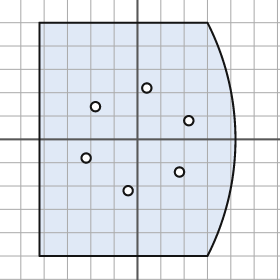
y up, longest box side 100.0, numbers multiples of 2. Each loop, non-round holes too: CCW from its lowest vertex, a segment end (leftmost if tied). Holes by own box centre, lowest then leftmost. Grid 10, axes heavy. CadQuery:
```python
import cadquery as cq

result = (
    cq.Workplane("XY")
    .moveTo(-42.0, -50.0)
    .lineTo(30.0, -50.0)
    .threePointArc((42.0, 0.0), (30.0, 50.0))
    .lineTo(-42.0, 50.0)
    .close()
    .moveTo(-4.0, -22.0)
    .circle(2.0)
    .moveTo(18.0, -14.0)
    .circle(2.0)
    .moveTo(-22.0, -8.0)
    .circle(2.0)
    .moveTo(22.0, 8.0)
    .circle(2.0)
    .moveTo(-18.0, 14.0)
    .circle(2.0)
    .moveTo(4.0, 22.0)
    .circle(2.0)
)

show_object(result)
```